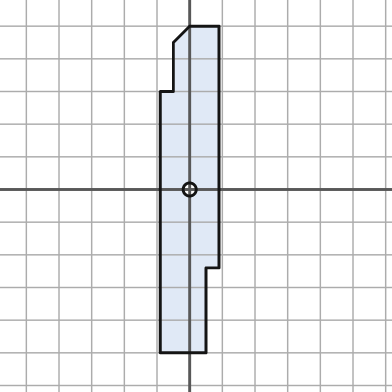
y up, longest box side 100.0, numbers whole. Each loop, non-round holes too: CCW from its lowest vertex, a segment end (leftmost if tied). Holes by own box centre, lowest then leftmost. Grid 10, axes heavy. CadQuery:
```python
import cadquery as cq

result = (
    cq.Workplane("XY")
    .moveTo(-9.0, -50.0)
    .lineTo(5.0, -50.0)
    .lineTo(5.0, -24.0)
    .lineTo(9.0, -24.0)
    .lineTo(9.0, 50.0)
    .lineTo(0.0, 50.0)
    .lineTo(-5.0, 45.0)
    .lineTo(-5.0, 30.0)
    .lineTo(-9.0, 30.0)
    .close()
    .moveTo(0.0, 0.0)
    .circle(2.0)
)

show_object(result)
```